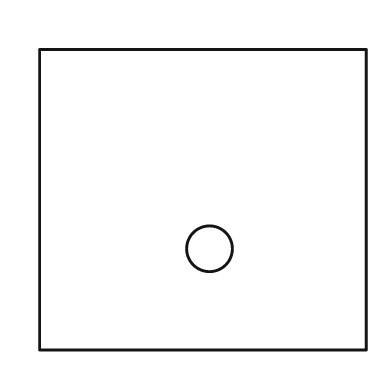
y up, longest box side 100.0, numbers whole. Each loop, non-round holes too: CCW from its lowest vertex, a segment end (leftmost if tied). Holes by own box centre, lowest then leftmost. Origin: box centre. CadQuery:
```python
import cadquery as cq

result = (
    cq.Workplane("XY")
    .moveTo(-50.0, -46.0)
    .lineTo(50.0, -46.0)
    .lineTo(50.0, 46.0)
    .lineTo(-50.0, 46.0)
    .close()
    .moveTo(2.0, -15.0)
    .circle(7.0)
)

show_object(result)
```